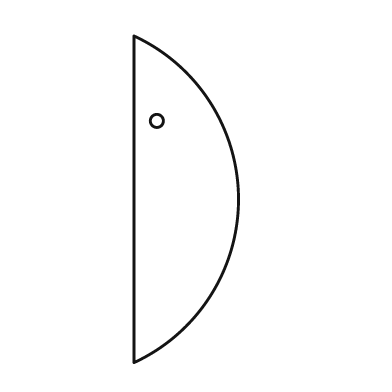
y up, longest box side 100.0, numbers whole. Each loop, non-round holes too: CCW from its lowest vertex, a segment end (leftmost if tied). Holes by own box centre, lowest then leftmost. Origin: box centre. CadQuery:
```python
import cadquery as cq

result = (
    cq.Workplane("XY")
    .moveTo(-16.0, -50.0)
    .threePointArc((16.0, 0.0), (-16.0, 50.0))
    .close()
    .moveTo(-9.0, 24.0)
    .circle(2.0)
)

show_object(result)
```